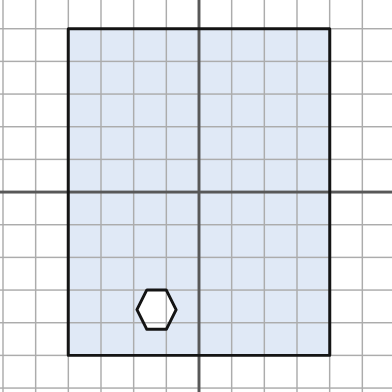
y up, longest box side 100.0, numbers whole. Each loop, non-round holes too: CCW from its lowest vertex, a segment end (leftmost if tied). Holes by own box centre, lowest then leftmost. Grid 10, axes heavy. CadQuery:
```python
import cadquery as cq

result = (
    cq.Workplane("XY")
    .moveTo(-40.0, -50.0)
    .lineTo(40.0, -50.0)
    .lineTo(40.0, 50.0)
    .lineTo(-40.0, 50.0)
    .close()
    .moveTo(-16.0, -42.0)
    .lineTo(-10.0, -42.0)
    .lineTo(-7.0, -36.0)
    .lineTo(-10.0, -30.0)
    .lineTo(-16.0, -30.0)
    .lineTo(-19.0, -36.0)
    .close()
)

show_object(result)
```